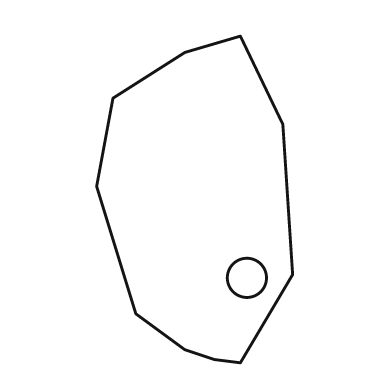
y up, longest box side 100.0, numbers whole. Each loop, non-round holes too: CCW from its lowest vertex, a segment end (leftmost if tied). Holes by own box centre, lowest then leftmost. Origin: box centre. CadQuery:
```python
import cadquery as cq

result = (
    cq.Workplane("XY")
    .moveTo(14.0, -50.0)
    .lineTo(30.0, -23.0)
    .lineTo(27.0, 23.0)
    .lineTo(14.0, 50.0)
    .lineTo(-3.0, 45.0)
    .lineTo(-25.0, 31.0)
    .lineTo(-30.0, 4.0)
    .lineTo(-18.0, -35.0)
    .lineTo(-3.0, -46.0)
    .lineTo(6.0, -49.0)
    .close()
    .moveTo(16.0, -24.0)
    .circle(6.0)
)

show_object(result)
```